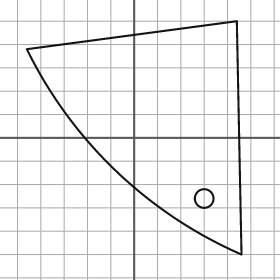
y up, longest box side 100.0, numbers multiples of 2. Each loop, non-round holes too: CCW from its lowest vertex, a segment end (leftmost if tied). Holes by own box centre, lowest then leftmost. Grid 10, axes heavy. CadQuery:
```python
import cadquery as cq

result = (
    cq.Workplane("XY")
    .moveTo(46.0, -50.0)
    .lineTo(44.0, 50.0)
    .lineTo(-46.0, 38.0)
    .threePointArc((-8.0, -14.0), (46.0, -50.0))
    .close()
    .moveTo(30.0, -26.0)
    .circle(4.0)
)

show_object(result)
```